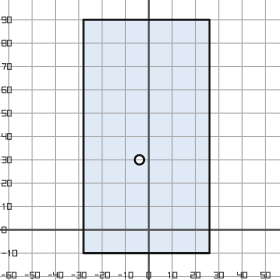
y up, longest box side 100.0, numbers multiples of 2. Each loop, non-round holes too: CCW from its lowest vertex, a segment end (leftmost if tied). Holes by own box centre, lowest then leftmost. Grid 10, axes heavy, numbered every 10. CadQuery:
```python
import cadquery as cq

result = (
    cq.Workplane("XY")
    .moveTo(-28.0, -10.0)
    .lineTo(26.0, -10.0)
    .lineTo(26.0, 90.0)
    .lineTo(-28.0, 90.0)
    .close()
    .moveTo(-4.0, 30.0)
    .circle(2.0)
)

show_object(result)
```